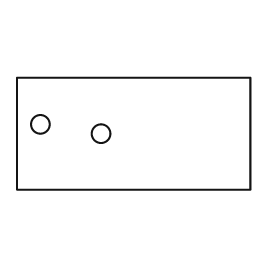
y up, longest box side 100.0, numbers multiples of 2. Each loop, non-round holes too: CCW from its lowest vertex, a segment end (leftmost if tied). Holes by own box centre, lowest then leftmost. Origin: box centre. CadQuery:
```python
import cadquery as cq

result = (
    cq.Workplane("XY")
    .moveTo(-50.0, -24.0)
    .lineTo(50.0, -24.0)
    .lineTo(50.0, 24.0)
    .lineTo(-50.0, 24.0)
    .close()
    .moveTo(-14.0, 0.0)
    .circle(4.0)
    .moveTo(-40.0, 4.0)
    .circle(4.0)
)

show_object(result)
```